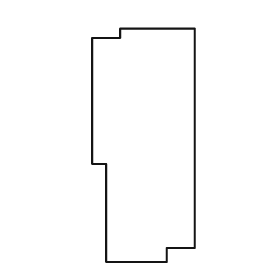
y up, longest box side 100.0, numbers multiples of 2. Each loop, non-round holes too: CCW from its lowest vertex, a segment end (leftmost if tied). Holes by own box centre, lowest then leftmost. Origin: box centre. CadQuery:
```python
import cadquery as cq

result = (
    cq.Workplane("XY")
    .moveTo(-16.0, -50.0)
    .lineTo(10.0, -50.0)
    .lineTo(10.0, -44.0)
    .lineTo(22.0, -44.0)
    .lineTo(22.0, 50.0)
    .lineTo(-10.0, 50.0)
    .lineTo(-10.0, 46.0)
    .lineTo(-22.0, 46.0)
    .lineTo(-22.0, -8.0)
    .lineTo(-16.0, -8.0)
    .close()
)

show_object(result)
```